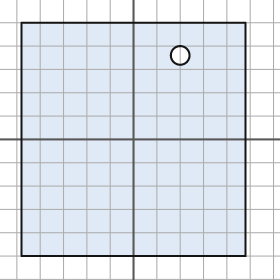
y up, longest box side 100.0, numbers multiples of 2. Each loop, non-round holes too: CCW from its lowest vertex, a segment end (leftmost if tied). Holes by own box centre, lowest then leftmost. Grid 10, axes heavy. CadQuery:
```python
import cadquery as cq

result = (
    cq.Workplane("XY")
    .moveTo(-48.0, -50.0)
    .lineTo(48.0, -50.0)
    .lineTo(48.0, 50.0)
    .lineTo(-48.0, 50.0)
    .close()
    .moveTo(20.0, 36.0)
    .circle(4.0)
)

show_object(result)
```